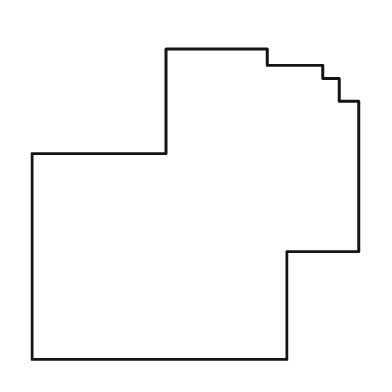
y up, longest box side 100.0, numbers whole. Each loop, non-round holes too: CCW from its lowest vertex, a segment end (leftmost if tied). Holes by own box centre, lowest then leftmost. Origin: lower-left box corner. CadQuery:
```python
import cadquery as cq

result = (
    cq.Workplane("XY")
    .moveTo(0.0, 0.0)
    .lineTo(78.0, 0.0)
    .lineTo(78.0, 33.0)
    .lineTo(100.0, 33.0)
    .lineTo(100.0, 79.0)
    .lineTo(94.0, 79.0)
    .lineTo(94.0, 86.0)
    .lineTo(89.0, 86.0)
    .lineTo(89.0, 90.0)
    .lineTo(72.0, 90.0)
    .lineTo(72.0, 95.0)
    .lineTo(41.0, 95.0)
    .lineTo(41.0, 63.0)
    .lineTo(0.0, 63.0)
    .close()
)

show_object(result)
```